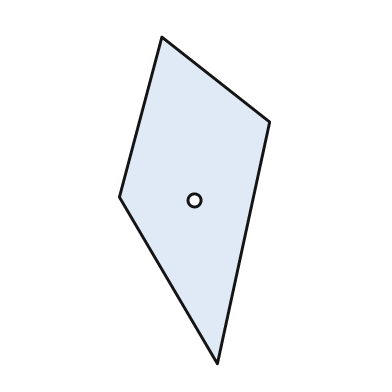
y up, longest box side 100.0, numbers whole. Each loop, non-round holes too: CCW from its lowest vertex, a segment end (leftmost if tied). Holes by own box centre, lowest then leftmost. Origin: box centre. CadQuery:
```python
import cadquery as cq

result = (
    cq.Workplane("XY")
    .moveTo(7.0, -50.0)
    .lineTo(23.0, 24.0)
    .lineTo(-10.0, 50.0)
    .lineTo(-23.0, 1.0)
    .close()
    .moveTo(0.0, 0.0)
    .circle(2.0)
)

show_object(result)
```